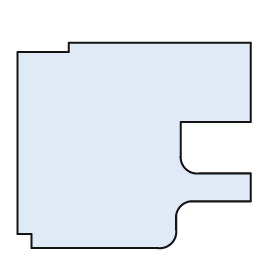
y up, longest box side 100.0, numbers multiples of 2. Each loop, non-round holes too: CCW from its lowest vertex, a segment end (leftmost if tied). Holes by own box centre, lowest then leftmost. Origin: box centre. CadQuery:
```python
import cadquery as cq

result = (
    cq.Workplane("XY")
    .moveTo(-44.0, -44.0)
    .lineTo(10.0, -44.0)
    .threePointArc((16.0, -42.0), (18.0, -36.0))
    .lineTo(18.0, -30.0)
    .threePointArc((20.0, -26.0), (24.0, -24.0))
    .lineTo(50.0, -24.0)
    .lineTo(50.0, -12.0)
    .lineTo(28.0, -12.0)
    .threePointArc((22.0, -10.0), (20.0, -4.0))
    .lineTo(20.0, 10.0)
    .lineTo(50.0, 10.0)
    .lineTo(50.0, 44.0)
    .lineTo(-28.0, 44.0)
    .lineTo(-28.0, 40.0)
    .lineTo(-50.0, 40.0)
    .lineTo(-50.0, -38.0)
    .lineTo(-44.0, -38.0)
    .close()
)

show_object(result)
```